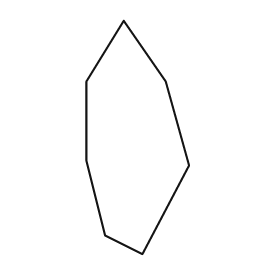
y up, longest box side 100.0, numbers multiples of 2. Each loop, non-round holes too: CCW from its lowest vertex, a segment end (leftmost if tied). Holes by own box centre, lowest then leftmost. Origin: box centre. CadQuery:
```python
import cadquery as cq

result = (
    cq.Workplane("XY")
    .moveTo(2.0, -50.0)
    .lineTo(22.0, -12.0)
    .lineTo(12.0, 24.0)
    .lineTo(-6.0, 50.0)
    .lineTo(-22.0, 24.0)
    .lineTo(-22.0, -10.0)
    .lineTo(-14.0, -42.0)
    .close()
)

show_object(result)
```